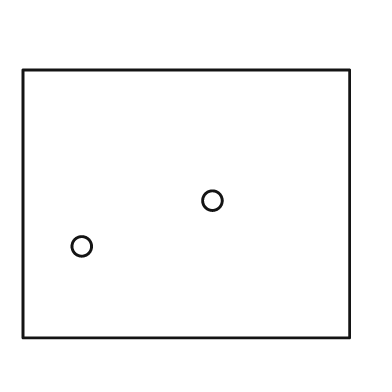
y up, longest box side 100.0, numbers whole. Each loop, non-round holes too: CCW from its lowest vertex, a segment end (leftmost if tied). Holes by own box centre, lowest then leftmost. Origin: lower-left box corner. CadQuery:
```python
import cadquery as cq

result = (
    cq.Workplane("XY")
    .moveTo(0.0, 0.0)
    .lineTo(100.0, 0.0)
    .lineTo(100.0, 82.0)
    .lineTo(0.0, 82.0)
    .close()
    .moveTo(18.0, 28.0)
    .circle(3.0)
    .moveTo(58.0, 42.0)
    .circle(3.0)
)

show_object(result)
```